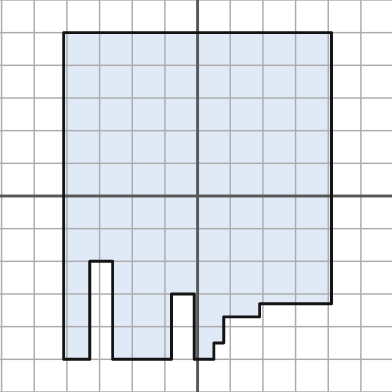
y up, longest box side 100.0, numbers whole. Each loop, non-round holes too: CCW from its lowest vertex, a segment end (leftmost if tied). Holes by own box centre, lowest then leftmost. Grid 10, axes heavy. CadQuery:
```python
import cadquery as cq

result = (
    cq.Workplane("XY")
    .moveTo(-41.0, -50.0)
    .lineTo(-33.0, -50.0)
    .lineTo(-33.0, -20.0)
    .lineTo(-26.0, -20.0)
    .lineTo(-26.0, -50.0)
    .lineTo(-8.0, -50.0)
    .lineTo(-8.0, -30.0)
    .lineTo(-1.0, -30.0)
    .lineTo(-1.0, -50.0)
    .lineTo(5.0, -50.0)
    .lineTo(5.0, -45.0)
    .lineTo(8.0, -45.0)
    .lineTo(8.0, -37.0)
    .lineTo(19.0, -37.0)
    .lineTo(19.0, -33.0)
    .lineTo(41.0, -33.0)
    .lineTo(41.0, 50.0)
    .lineTo(-41.0, 50.0)
    .close()
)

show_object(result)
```